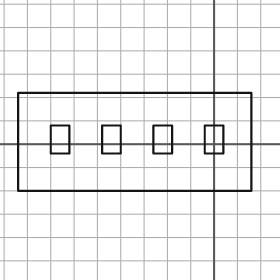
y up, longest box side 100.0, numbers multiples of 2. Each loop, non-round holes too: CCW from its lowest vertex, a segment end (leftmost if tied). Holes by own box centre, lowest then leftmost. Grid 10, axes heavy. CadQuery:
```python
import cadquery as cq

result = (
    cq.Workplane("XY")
    .moveTo(-84.0, -20.0)
    .lineTo(16.0, -20.0)
    .lineTo(16.0, 22.0)
    .lineTo(-84.0, 22.0)
    .close()
    .moveTo(-70.0, -4.0)
    .lineTo(-62.0, -4.0)
    .lineTo(-62.0, 8.0)
    .lineTo(-70.0, 8.0)
    .close()
    .moveTo(-48.0, -4.0)
    .lineTo(-40.0, -4.0)
    .lineTo(-40.0, 8.0)
    .lineTo(-48.0, 8.0)
    .close()
    .moveTo(-26.0, -4.0)
    .lineTo(-18.0, -4.0)
    .lineTo(-18.0, 8.0)
    .lineTo(-26.0, 8.0)
    .close()
    .moveTo(-4.0, -4.0)
    .lineTo(4.0, -4.0)
    .lineTo(4.0, 8.0)
    .lineTo(-4.0, 8.0)
    .close()
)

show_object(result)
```